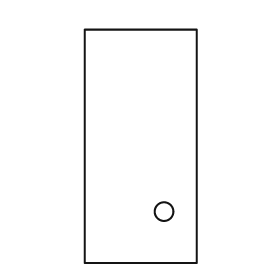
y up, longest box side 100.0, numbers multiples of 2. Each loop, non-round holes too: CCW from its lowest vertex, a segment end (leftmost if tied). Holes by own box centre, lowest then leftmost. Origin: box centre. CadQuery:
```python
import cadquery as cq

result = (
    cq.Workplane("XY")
    .moveTo(-24.0, -50.0)
    .lineTo(24.0, -50.0)
    .lineTo(24.0, 50.0)
    .lineTo(-24.0, 50.0)
    .close()
    .moveTo(10.0, -28.0)
    .circle(4.0)
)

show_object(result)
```